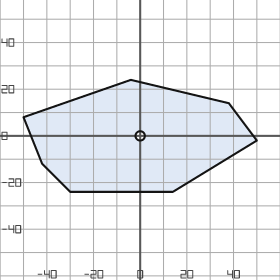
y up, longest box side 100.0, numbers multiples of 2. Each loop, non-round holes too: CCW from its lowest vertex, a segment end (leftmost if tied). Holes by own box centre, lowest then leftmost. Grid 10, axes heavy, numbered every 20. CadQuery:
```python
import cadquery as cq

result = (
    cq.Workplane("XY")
    .moveTo(-30.0, -24.0)
    .lineTo(14.0, -24.0)
    .lineTo(50.0, -2.0)
    .lineTo(38.0, 14.0)
    .lineTo(-4.0, 24.0)
    .lineTo(-50.0, 8.0)
    .lineTo(-42.0, -12.0)
    .close()
    .moveTo(0.0, 0.0)
    .circle(2.0)
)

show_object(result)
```